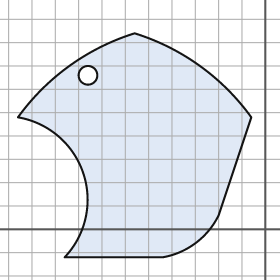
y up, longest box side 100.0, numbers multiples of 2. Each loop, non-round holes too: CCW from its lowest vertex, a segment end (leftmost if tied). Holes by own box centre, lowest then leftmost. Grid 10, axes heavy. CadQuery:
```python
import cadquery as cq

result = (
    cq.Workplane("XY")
    .moveTo(-86.0, -12.0)
    .lineTo(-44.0, -12.0)
    .threePointArc((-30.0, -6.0), (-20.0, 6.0))
    .lineTo(-6.0, 48.0)
    .threePointArc((-28.0, 70.0), (-56.0, 84.0))
    .threePointArc((-84.0, 70.0), (-106.0, 48.0))
    .threePointArc((-78.0, 24.0), (-86.0, -12.0))
    .close()
    .moveTo(-76.0, 66.0)
    .circle(4.0)
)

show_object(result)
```